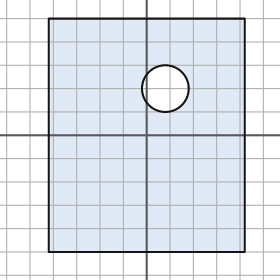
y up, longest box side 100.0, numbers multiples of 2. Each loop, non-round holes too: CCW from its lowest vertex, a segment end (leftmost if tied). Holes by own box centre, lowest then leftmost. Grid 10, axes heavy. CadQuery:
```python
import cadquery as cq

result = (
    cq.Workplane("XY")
    .moveTo(-42.0, -50.0)
    .lineTo(42.0, -50.0)
    .lineTo(42.0, 50.0)
    .lineTo(-42.0, 50.0)
    .close()
    .moveTo(8.0, 20.0)
    .circle(10.0)
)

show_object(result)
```